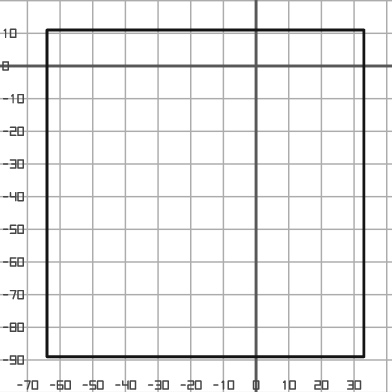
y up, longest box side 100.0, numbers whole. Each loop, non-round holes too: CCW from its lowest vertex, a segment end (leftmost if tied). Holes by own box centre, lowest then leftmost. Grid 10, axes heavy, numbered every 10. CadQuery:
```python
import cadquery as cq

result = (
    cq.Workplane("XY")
    .moveTo(-64.0, -89.0)
    .lineTo(33.0, -89.0)
    .lineTo(33.0, 11.0)
    .lineTo(-64.0, 11.0)
    .close()
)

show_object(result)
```